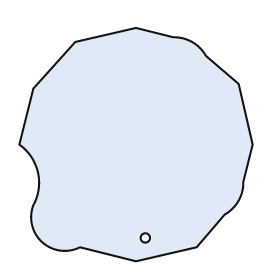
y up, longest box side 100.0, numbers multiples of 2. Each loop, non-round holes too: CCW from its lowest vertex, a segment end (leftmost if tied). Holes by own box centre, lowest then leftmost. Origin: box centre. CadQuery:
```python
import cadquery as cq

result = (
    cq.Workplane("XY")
    .moveTo(0.0, -50.0)
    .lineTo(26.0, -44.0)
    .lineTo(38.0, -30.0)
    .threePointArc((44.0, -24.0), (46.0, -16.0))
    .lineTo(50.0, 0.0)
    .lineTo(44.0, 26.0)
    .lineTo(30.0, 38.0)
    .threePointArc((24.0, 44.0), (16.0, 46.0))
    .lineTo(0.0, 50.0)
    .lineTo(-26.0, 44.0)
    .lineTo(-44.0, 24.0)
    .lineTo(-50.0, 0.0)
    .threePointArc((-42.0, -12.0), (-44.0, -26.0))
    .threePointArc((-40.0, -42.0), (-24.0, -44.0))
    .close()
    .moveTo(4.0, -40.0)
    .circle(2.0)
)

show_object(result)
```